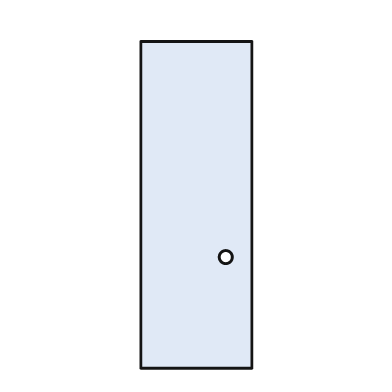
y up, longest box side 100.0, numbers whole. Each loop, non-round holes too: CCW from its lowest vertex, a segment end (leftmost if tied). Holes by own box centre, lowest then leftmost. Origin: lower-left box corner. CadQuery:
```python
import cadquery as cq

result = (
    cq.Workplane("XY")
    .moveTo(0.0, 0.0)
    .lineTo(34.0, 0.0)
    .lineTo(34.0, 100.0)
    .lineTo(0.0, 100.0)
    .close()
    .moveTo(26.0, 34.0)
    .circle(2.0)
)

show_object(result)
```